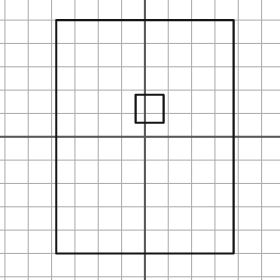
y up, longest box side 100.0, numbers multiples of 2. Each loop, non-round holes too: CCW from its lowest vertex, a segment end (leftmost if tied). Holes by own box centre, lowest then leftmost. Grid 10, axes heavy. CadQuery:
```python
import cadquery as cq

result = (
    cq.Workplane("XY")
    .moveTo(-38.0, -50.0)
    .lineTo(38.0, -50.0)
    .lineTo(38.0, 50.0)
    .lineTo(-38.0, 50.0)
    .close()
    .moveTo(-4.0, 6.0)
    .lineTo(8.0, 6.0)
    .lineTo(8.0, 18.0)
    .lineTo(-4.0, 18.0)
    .close()
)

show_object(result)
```